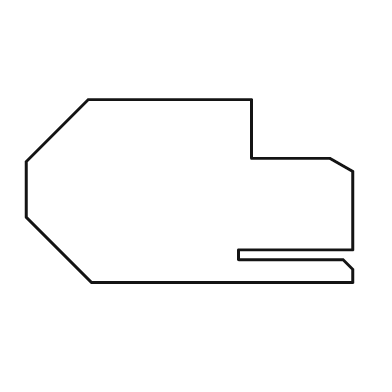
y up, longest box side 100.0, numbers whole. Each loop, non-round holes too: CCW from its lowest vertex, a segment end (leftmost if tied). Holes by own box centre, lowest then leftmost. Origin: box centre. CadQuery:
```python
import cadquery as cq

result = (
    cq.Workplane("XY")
    .moveTo(-30.0, -28.0)
    .lineTo(50.0, -28.0)
    .lineTo(50.0, -24.0)
    .lineTo(47.0, -21.0)
    .lineTo(15.0, -21.0)
    .lineTo(15.0, -18.0)
    .lineTo(50.0, -18.0)
    .lineTo(50.0, 6.0)
    .lineTo(43.0, 10.0)
    .lineTo(19.0, 10.0)
    .lineTo(19.0, 28.0)
    .lineTo(-31.0, 28.0)
    .lineTo(-50.0, 9.0)
    .lineTo(-50.0, -8.0)
    .close()
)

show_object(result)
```